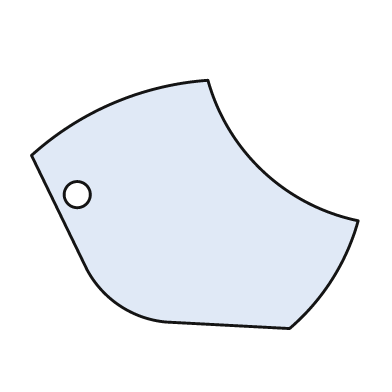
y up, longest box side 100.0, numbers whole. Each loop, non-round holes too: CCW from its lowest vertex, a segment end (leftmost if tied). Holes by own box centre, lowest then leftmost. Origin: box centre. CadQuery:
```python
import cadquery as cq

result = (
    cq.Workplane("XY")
    .moveTo(29.0, -38.0)
    .threePointArc((42.0, -23.0), (50.0, -5.0))
    .threePointArc((21.0, 10.0), (4.0, 38.0))
    .threePointArc((-25.0, 31.0), (-50.0, 15.0))
    .lineTo(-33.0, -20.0)
    .threePointArc((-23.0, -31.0), (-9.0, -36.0))
    .close()
    .moveTo(-36.0, 3.0)
    .circle(4.0)
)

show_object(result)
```